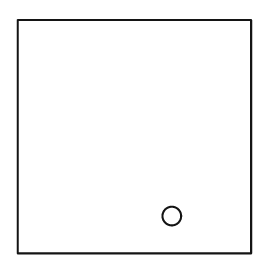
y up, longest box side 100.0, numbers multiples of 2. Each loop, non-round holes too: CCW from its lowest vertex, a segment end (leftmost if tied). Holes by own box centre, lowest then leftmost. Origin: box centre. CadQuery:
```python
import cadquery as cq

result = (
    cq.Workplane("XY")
    .moveTo(-50.0, -50.0)
    .lineTo(50.0, -50.0)
    .lineTo(50.0, 50.0)
    .lineTo(-50.0, 50.0)
    .close()
    .moveTo(16.0, -34.0)
    .circle(4.0)
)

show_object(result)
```